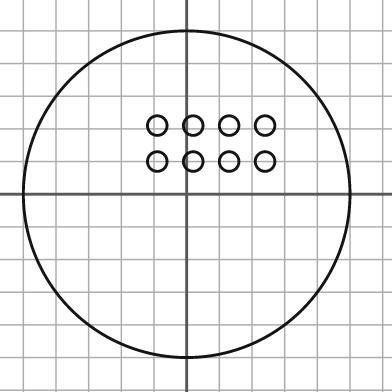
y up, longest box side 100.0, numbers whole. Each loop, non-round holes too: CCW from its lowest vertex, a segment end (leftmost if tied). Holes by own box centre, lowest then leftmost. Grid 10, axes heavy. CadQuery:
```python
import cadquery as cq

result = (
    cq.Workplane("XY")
    .moveTo(0.0, 0.0)
    .circle(50.0)
    .moveTo(-9.0, 10.0)
    .circle(3.0)
    .moveTo(2.0, 10.0)
    .circle(3.0)
    .moveTo(13.0, 10.0)
    .circle(3.0)
    .moveTo(24.0, 10.0)
    .circle(3.0)
    .moveTo(-9.0, 21.0)
    .circle(3.0)
    .moveTo(2.0, 21.0)
    .circle(3.0)
    .moveTo(13.0, 21.0)
    .circle(3.0)
    .moveTo(24.0, 21.0)
    .circle(3.0)
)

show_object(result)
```